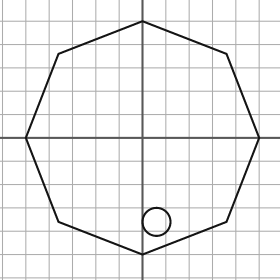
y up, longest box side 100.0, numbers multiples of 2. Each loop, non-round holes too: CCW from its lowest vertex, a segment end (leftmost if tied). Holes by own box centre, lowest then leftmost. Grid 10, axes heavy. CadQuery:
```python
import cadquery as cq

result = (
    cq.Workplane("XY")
    .moveTo(0.0, -50.0)
    .lineTo(36.0, -36.0)
    .lineTo(50.0, 0.0)
    .lineTo(36.0, 36.0)
    .lineTo(0.0, 50.0)
    .lineTo(-36.0, 36.0)
    .lineTo(-50.0, 0.0)
    .lineTo(-36.0, -36.0)
    .close()
    .moveTo(6.0, -36.0)
    .circle(6.0)
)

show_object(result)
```